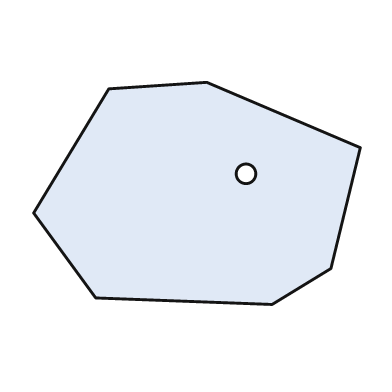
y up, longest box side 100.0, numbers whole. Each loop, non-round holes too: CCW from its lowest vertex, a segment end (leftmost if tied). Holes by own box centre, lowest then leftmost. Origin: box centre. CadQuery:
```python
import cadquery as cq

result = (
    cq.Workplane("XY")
    .moveTo(23.0, -34.0)
    .lineTo(41.0, -23.0)
    .lineTo(50.0, 14.0)
    .lineTo(3.0, 34.0)
    .lineTo(-27.0, 32.0)
    .lineTo(-50.0, -6.0)
    .lineTo(-31.0, -32.0)
    .close()
    .moveTo(15.0, 6.0)
    .circle(3.0)
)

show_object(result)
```